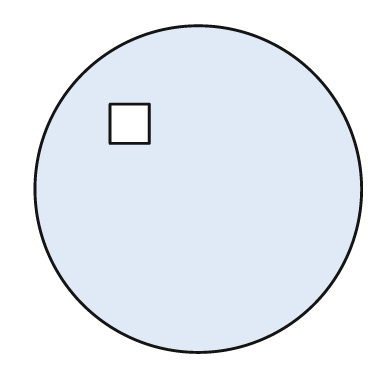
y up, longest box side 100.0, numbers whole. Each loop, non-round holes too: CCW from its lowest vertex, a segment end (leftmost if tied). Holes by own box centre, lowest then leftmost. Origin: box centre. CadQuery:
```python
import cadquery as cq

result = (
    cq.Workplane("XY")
    .moveTo(0.0, 0.0)
    .circle(50.0)
    .moveTo(-27.0, 14.0)
    .lineTo(-15.0, 14.0)
    .lineTo(-15.0, 26.0)
    .lineTo(-27.0, 26.0)
    .close()
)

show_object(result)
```